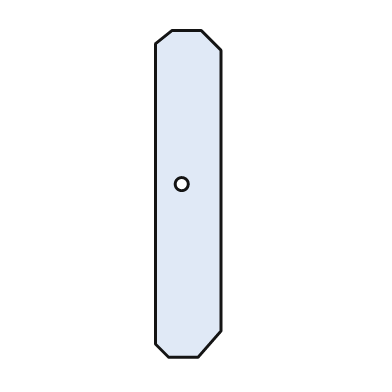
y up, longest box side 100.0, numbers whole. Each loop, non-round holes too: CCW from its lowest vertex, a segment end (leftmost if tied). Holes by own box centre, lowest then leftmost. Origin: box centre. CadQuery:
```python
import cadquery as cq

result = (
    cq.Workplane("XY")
    .moveTo(-6.0, -50.0)
    .lineTo(3.0, -50.0)
    .lineTo(10.0, -42.0)
    .lineTo(10.0, 44.0)
    .lineTo(4.0, 50.0)
    .lineTo(-5.0, 50.0)
    .lineTo(-10.0, 46.0)
    .lineTo(-10.0, -46.0)
    .close()
    .moveTo(-2.0, 3.0)
    .circle(2.0)
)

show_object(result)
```